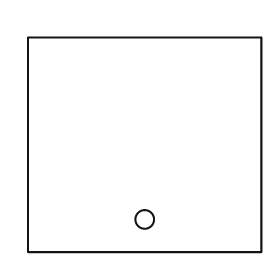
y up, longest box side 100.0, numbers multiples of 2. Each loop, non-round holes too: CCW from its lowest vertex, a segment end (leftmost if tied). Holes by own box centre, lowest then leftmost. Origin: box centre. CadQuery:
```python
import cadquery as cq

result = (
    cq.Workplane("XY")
    .moveTo(-50.0, -46.0)
    .lineTo(50.0, -46.0)
    .lineTo(50.0, 46.0)
    .lineTo(-50.0, 46.0)
    .close()
    .moveTo(0.0, -32.0)
    .circle(4.0)
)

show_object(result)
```